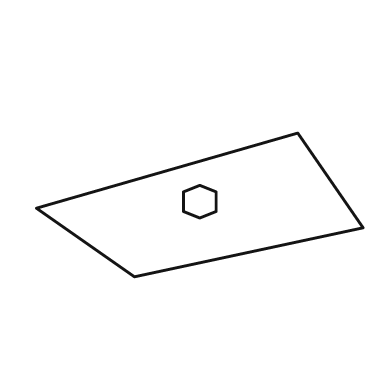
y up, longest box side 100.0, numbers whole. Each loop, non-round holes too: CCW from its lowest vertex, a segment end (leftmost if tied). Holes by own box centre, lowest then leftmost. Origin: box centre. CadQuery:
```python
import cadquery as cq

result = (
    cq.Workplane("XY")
    .moveTo(-20.0, -22.0)
    .lineTo(50.0, -7.0)
    .lineTo(30.0, 22.0)
    .lineTo(-50.0, -1.0)
    .close()
    .moveTo(0.0, -4.0)
    .lineTo(5.0, -2.0)
    .lineTo(5.0, 4.0)
    .lineTo(0.0, 6.0)
    .lineTo(-5.0, 4.0)
    .lineTo(-5.0, -2.0)
    .close()
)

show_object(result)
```